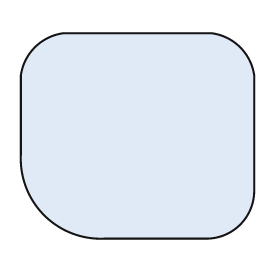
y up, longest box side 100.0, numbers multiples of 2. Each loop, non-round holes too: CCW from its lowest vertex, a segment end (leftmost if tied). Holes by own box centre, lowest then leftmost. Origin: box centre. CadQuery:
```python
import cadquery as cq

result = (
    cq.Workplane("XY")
    .moveTo(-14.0, -44.0)
    .lineTo(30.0, -44.0)
    .threePointArc((44.0, -38.0), (50.0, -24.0))
    .lineTo(50.0, 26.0)
    .threePointArc((44.0, 38.0), (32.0, 44.0))
    .lineTo(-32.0, 44.0)
    .threePointArc((-44.0, 38.0), (-50.0, 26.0))
    .lineTo(-50.0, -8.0)
    .threePointArc((-40.0, -34.0), (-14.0, -44.0))
    .close()
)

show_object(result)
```